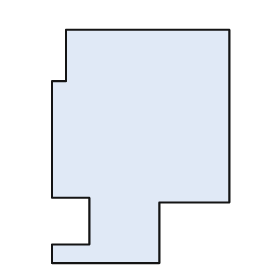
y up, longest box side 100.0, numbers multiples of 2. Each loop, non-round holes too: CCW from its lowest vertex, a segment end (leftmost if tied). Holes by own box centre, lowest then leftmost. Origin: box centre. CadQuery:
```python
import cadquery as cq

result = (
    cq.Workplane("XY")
    .moveTo(-38.0, -50.0)
    .lineTo(8.0, -50.0)
    .lineTo(8.0, -24.0)
    .lineTo(38.0, -24.0)
    .lineTo(38.0, 50.0)
    .lineTo(-32.0, 50.0)
    .lineTo(-32.0, 28.0)
    .lineTo(-38.0, 28.0)
    .lineTo(-38.0, -22.0)
    .lineTo(-22.0, -22.0)
    .lineTo(-22.0, -42.0)
    .lineTo(-38.0, -42.0)
    .close()
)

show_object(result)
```